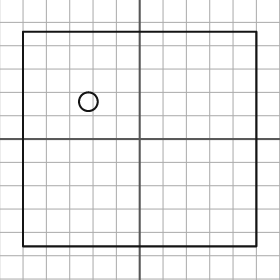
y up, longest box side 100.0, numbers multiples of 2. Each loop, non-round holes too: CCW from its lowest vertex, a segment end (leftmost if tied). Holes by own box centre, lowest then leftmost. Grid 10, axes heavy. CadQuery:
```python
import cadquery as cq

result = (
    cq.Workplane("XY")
    .moveTo(-50.0, -46.0)
    .lineTo(50.0, -46.0)
    .lineTo(50.0, 46.0)
    .lineTo(-50.0, 46.0)
    .close()
    .moveTo(-22.0, 16.0)
    .circle(4.0)
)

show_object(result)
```